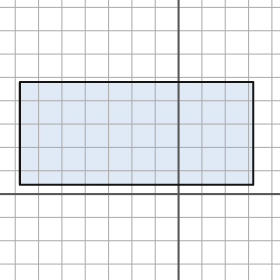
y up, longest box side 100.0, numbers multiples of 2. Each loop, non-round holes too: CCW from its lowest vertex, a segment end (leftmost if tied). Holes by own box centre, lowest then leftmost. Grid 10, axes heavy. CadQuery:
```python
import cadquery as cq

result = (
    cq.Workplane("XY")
    .moveTo(-68.0, 4.0)
    .lineTo(32.0, 4.0)
    .lineTo(32.0, 48.0)
    .lineTo(-68.0, 48.0)
    .close()
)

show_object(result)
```